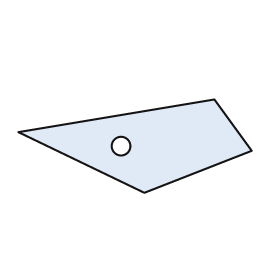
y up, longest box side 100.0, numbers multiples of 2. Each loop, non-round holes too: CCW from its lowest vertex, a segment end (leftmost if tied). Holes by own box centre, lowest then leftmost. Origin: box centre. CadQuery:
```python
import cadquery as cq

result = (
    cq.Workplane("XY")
    .moveTo(4.0, -20.0)
    .lineTo(50.0, -2.0)
    .lineTo(34.0, 20.0)
    .lineTo(-50.0, 6.0)
    .close()
    .moveTo(-6.0, 0.0)
    .circle(4.0)
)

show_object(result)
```